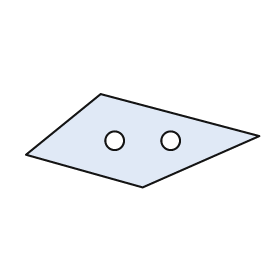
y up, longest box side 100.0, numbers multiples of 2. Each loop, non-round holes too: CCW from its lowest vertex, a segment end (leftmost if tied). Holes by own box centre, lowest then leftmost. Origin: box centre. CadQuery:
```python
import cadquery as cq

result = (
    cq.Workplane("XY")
    .moveTo(0.0, -20.0)
    .lineTo(50.0, 2.0)
    .lineTo(-18.0, 20.0)
    .lineTo(-50.0, -6.0)
    .close()
    .moveTo(-12.0, 0.0)
    .circle(4.0)
    .moveTo(12.0, 0.0)
    .circle(4.0)
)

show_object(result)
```